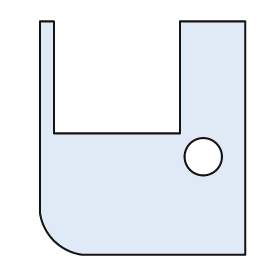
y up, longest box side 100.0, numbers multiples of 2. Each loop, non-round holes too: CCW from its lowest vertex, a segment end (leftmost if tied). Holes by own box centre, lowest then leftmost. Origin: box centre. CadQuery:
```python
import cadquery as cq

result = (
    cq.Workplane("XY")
    .moveTo(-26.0, -50.0)
    .lineTo(44.0, -50.0)
    .lineTo(44.0, 50.0)
    .lineTo(16.0, 50.0)
    .lineTo(16.0, 2.0)
    .lineTo(-38.0, 2.0)
    .lineTo(-38.0, 50.0)
    .lineTo(-44.0, 50.0)
    .lineTo(-44.0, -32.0)
    .threePointArc((-38.0, -44.0), (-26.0, -50.0))
    .close()
    .moveTo(26.0, -8.0)
    .circle(8.0)
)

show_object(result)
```